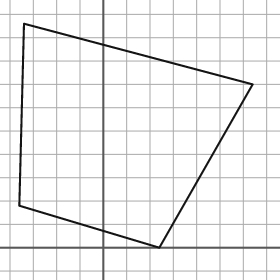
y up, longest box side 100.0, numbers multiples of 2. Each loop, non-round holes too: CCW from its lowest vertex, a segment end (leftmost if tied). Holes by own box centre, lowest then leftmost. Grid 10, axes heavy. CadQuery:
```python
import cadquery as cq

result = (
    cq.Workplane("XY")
    .moveTo(24.0, 0.0)
    .lineTo(64.0, 70.0)
    .lineTo(-34.0, 96.0)
    .lineTo(-36.0, 18.0)
    .close()
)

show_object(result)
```